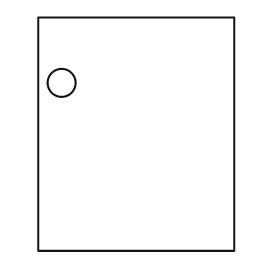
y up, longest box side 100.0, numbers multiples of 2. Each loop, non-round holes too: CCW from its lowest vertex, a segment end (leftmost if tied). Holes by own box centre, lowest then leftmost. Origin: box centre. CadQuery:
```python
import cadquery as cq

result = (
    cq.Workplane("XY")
    .moveTo(-42.0, -50.0)
    .lineTo(42.0, -50.0)
    .lineTo(42.0, 50.0)
    .lineTo(-42.0, 50.0)
    .close()
    .moveTo(-32.0, 22.0)
    .circle(6.0)
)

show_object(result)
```